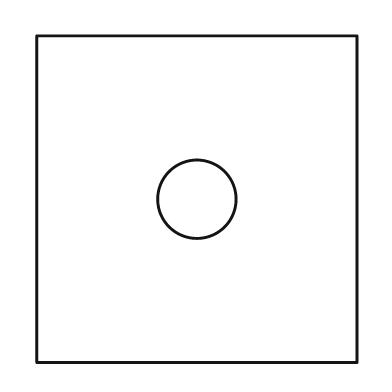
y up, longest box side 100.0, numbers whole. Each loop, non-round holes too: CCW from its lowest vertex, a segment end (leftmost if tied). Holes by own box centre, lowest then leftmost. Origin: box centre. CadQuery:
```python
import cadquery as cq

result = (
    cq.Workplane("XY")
    .moveTo(-49.0, -50.0)
    .lineTo(49.0, -50.0)
    .lineTo(49.0, 50.0)
    .lineTo(-49.0, 50.0)
    .close()
    .moveTo(0.0, 0.0)
    .circle(12.0)
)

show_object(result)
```